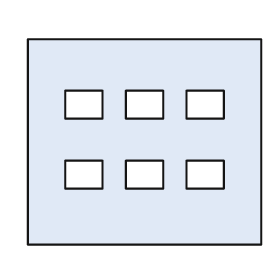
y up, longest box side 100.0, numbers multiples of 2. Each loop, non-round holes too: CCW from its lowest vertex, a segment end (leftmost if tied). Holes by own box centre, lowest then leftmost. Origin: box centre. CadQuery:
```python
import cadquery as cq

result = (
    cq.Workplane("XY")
    .moveTo(-50.0, -44.0)
    .lineTo(50.0, -44.0)
    .lineTo(50.0, 44.0)
    .lineTo(-50.0, 44.0)
    .close()
    .moveTo(-34.0, -20.0)
    .lineTo(-18.0, -20.0)
    .lineTo(-18.0, -8.0)
    .lineTo(-34.0, -8.0)
    .close()
    .moveTo(-8.0, -20.0)
    .lineTo(8.0, -20.0)
    .lineTo(8.0, -8.0)
    .lineTo(-8.0, -8.0)
    .close()
    .moveTo(18.0, -20.0)
    .lineTo(34.0, -20.0)
    .lineTo(34.0, -8.0)
    .lineTo(18.0, -8.0)
    .close()
    .moveTo(-34.0, 10.0)
    .lineTo(-18.0, 10.0)
    .lineTo(-18.0, 22.0)
    .lineTo(-34.0, 22.0)
    .close()
    .moveTo(-8.0, 10.0)
    .lineTo(8.0, 10.0)
    .lineTo(8.0, 22.0)
    .lineTo(-8.0, 22.0)
    .close()
    .moveTo(18.0, 10.0)
    .lineTo(34.0, 10.0)
    .lineTo(34.0, 22.0)
    .lineTo(18.0, 22.0)
    .close()
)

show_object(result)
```